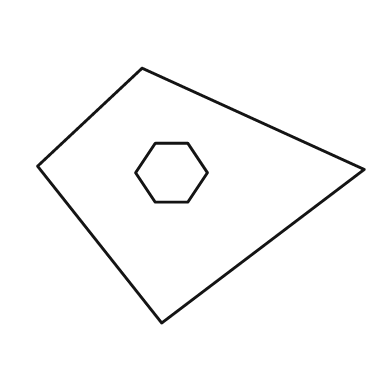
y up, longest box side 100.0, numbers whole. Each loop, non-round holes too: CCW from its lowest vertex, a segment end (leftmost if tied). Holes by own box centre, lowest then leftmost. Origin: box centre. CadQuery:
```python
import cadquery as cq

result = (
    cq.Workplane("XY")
    .moveTo(-12.0, -39.0)
    .lineTo(50.0, 8.0)
    .lineTo(-18.0, 39.0)
    .lineTo(-50.0, 9.0)
    .close()
    .moveTo(-14.0, -2.0)
    .lineTo(-4.0, -2.0)
    .lineTo(2.0, 7.0)
    .lineTo(-4.0, 16.0)
    .lineTo(-14.0, 16.0)
    .lineTo(-20.0, 7.0)
    .close()
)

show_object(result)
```